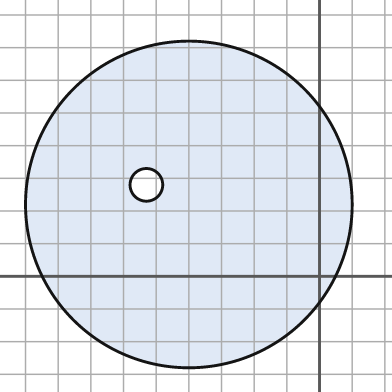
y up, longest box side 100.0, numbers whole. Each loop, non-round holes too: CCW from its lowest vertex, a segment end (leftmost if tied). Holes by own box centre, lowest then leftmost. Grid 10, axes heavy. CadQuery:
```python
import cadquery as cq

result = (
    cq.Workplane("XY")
    .moveTo(-40.0, 22.0)
    .circle(50.0)
    .moveTo(-53.0, 28.0)
    .circle(5.0)
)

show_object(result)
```